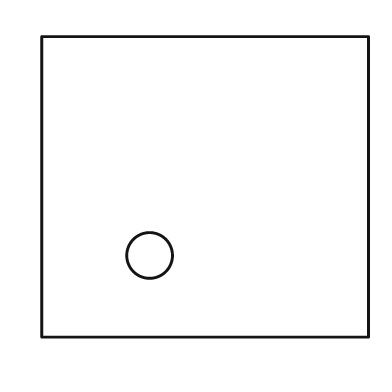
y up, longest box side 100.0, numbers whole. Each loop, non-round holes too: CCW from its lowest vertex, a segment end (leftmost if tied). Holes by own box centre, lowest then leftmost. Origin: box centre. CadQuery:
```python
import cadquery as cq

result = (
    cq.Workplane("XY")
    .moveTo(-50.0, -46.0)
    .lineTo(50.0, -46.0)
    .lineTo(50.0, 46.0)
    .lineTo(-50.0, 46.0)
    .close()
    .moveTo(-17.0, -21.0)
    .circle(7.0)
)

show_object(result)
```